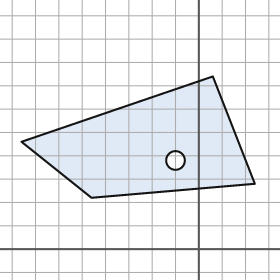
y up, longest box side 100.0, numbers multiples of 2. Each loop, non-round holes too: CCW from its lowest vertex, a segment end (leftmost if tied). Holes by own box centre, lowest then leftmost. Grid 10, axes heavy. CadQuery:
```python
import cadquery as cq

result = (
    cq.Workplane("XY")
    .moveTo(-46.0, 22.0)
    .lineTo(24.0, 28.0)
    .lineTo(6.0, 74.0)
    .lineTo(-76.0, 46.0)
    .close()
    .moveTo(-10.0, 38.0)
    .circle(4.0)
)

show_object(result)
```